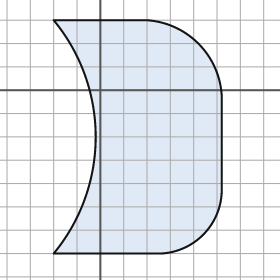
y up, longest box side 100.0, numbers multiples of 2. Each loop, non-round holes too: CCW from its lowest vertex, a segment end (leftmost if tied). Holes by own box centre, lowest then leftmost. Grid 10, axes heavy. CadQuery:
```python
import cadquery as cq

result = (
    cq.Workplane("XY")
    .moveTo(-20.0, -70.0)
    .lineTo(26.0, -70.0)
    .threePointArc((44.0, -62.0), (52.0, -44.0))
    .lineTo(52.0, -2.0)
    .threePointArc((42.0, 20.0), (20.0, 30.0))
    .lineTo(-20.0, 30.0)
    .threePointArc((-2.0, -20.0), (-20.0, -70.0))
    .close()
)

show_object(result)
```